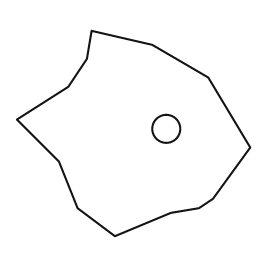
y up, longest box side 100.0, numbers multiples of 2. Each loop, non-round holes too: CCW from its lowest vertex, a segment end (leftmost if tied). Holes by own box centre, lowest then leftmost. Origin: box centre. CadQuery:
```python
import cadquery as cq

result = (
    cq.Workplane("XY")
    .moveTo(-8.0, -44.0)
    .lineTo(16.0, -34.0)
    .lineTo(28.0, -32.0)
    .lineTo(34.0, -28.0)
    .lineTo(50.0, -6.0)
    .lineTo(32.0, 24.0)
    .lineTo(8.0, 38.0)
    .lineTo(-18.0, 44.0)
    .lineTo(-20.0, 32.0)
    .lineTo(-28.0, 20.0)
    .lineTo(-50.0, 6.0)
    .lineTo(-32.0, -12.0)
    .lineTo(-24.0, -32.0)
    .close()
    .moveTo(14.0, 2.0)
    .circle(6.0)
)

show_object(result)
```